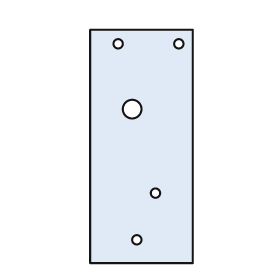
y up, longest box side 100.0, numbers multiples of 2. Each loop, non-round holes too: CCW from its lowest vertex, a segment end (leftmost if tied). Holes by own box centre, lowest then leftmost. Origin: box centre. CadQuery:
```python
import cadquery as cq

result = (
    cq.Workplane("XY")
    .moveTo(-22.0, -50.0)
    .lineTo(22.0, -50.0)
    .lineTo(22.0, 50.0)
    .lineTo(-22.0, 50.0)
    .close()
    .moveTo(-2.0, -40.0)
    .circle(2.0)
    .moveTo(6.0, -20.0)
    .circle(2.0)
    .moveTo(-4.0, 16.0)
    .circle(4.0)
    .moveTo(-10.0, 44.0)
    .circle(2.0)
    .moveTo(16.0, 44.0)
    .circle(2.0)
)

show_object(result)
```